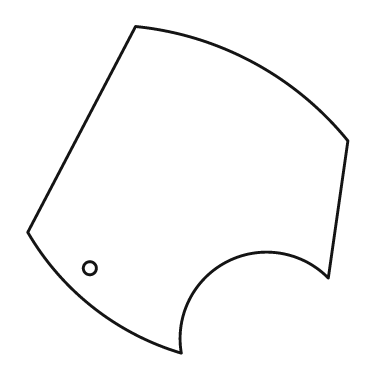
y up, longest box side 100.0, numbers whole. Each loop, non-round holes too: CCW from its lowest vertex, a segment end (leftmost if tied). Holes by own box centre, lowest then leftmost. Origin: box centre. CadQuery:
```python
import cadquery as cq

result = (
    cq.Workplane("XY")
    .moveTo(-2.0, -50.0)
    .threePointArc((12.0, -22.0), (43.0, -27.0))
    .lineTo(49.0, 15.0)
    .threePointArc((20.0, 39.0), (-16.0, 50.0))
    .lineTo(-49.0, -13.0)
    .threePointArc((-29.0, -36.0), (-2.0, -50.0))
    .close()
    .moveTo(-30.0, -24.0)
    .circle(2.0)
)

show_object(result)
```